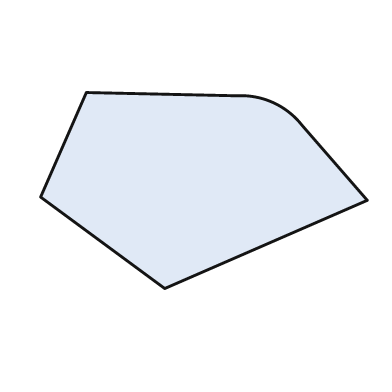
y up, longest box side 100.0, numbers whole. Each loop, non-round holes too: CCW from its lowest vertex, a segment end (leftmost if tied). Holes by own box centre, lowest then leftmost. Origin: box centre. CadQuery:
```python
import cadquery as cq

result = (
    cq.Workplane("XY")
    .moveTo(-12.0, -30.0)
    .lineTo(50.0, -3.0)
    .lineTo(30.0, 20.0)
    .threePointArc((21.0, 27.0), (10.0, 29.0))
    .lineTo(-36.0, 30.0)
    .lineTo(-50.0, -2.0)
    .close()
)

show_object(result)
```